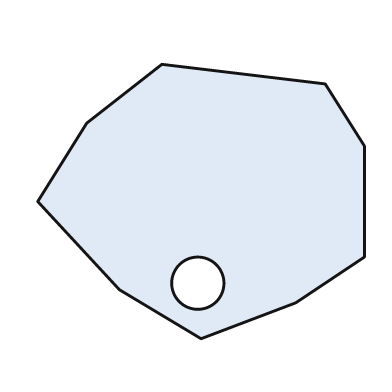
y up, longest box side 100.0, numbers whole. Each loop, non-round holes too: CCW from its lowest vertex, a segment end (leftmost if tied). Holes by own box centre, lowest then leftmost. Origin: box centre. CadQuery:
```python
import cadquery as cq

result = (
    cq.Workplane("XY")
    .moveTo(0.0, -42.0)
    .lineTo(29.0, -31.0)
    .lineTo(50.0, -17.0)
    .lineTo(50.0, 17.0)
    .lineTo(38.0, 36.0)
    .lineTo(-12.0, 42.0)
    .lineTo(-35.0, 24.0)
    .lineTo(-50.0, 0.0)
    .lineTo(-25.0, -27.0)
    .close()
    .moveTo(-1.0, -25.0)
    .circle(8.0)
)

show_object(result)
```